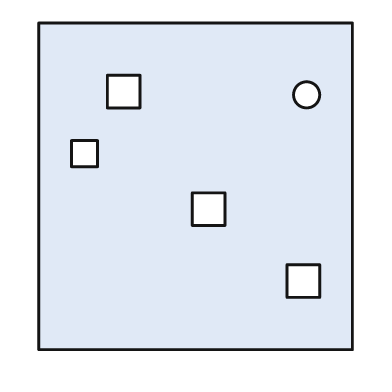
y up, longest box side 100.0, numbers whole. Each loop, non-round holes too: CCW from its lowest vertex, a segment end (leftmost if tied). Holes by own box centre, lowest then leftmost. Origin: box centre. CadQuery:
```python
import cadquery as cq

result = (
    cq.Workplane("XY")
    .moveTo(-48.0, -50.0)
    .lineTo(48.0, -50.0)
    .lineTo(48.0, 50.0)
    .lineTo(-48.0, 50.0)
    .close()
    .moveTo(28.0, -34.0)
    .lineTo(38.0, -34.0)
    .lineTo(38.0, -24.0)
    .lineTo(28.0, -24.0)
    .close()
    .moveTo(-1.0, -12.0)
    .lineTo(9.0, -12.0)
    .lineTo(9.0, -2.0)
    .lineTo(-1.0, -2.0)
    .close()
    .moveTo(-38.0, 6.0)
    .lineTo(-30.0, 6.0)
    .lineTo(-30.0, 14.0)
    .lineTo(-38.0, 14.0)
    .close()
    .moveTo(34.0, 28.0)
    .circle(4.0)
    .moveTo(-27.0, 24.0)
    .lineTo(-17.0, 24.0)
    .lineTo(-17.0, 34.0)
    .lineTo(-27.0, 34.0)
    .close()
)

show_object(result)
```